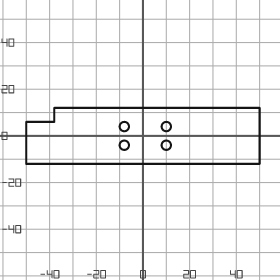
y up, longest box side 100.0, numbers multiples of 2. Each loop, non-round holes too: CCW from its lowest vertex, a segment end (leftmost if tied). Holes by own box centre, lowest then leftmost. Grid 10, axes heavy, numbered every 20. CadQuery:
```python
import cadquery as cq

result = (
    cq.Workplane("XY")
    .moveTo(-50.0, -12.0)
    .lineTo(50.0, -12.0)
    .lineTo(50.0, 12.0)
    .lineTo(-38.0, 12.0)
    .lineTo(-38.0, 6.0)
    .lineTo(-50.0, 6.0)
    .close()
    .moveTo(-8.0, -4.0)
    .circle(2.0)
    .moveTo(10.0, -4.0)
    .circle(2.0)
    .moveTo(-8.0, 4.0)
    .circle(2.0)
    .moveTo(10.0, 4.0)
    .circle(2.0)
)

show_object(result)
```